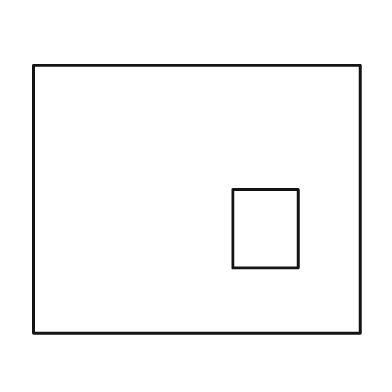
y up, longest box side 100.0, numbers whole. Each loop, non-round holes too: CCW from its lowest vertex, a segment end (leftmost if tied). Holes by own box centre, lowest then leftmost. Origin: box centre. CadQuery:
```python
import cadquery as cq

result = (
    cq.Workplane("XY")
    .moveTo(-50.0, -41.0)
    .lineTo(50.0, -41.0)
    .lineTo(50.0, 41.0)
    .lineTo(-50.0, 41.0)
    .close()
    .moveTo(11.0, -21.0)
    .lineTo(31.0, -21.0)
    .lineTo(31.0, 3.0)
    .lineTo(11.0, 3.0)
    .close()
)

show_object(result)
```